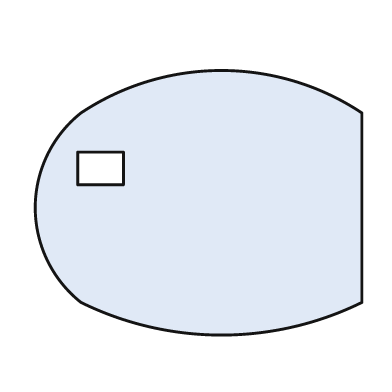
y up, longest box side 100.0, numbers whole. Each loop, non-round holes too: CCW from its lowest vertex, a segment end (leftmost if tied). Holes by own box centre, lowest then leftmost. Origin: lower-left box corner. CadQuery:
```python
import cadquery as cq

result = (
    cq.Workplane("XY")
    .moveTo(14.0, 10.0)
    .threePointArc((57.0, 0.0), (100.0, 10.0))
    .lineTo(100.0, 68.0)
    .threePointArc((57.0, 81.0), (14.0, 68.0))
    .threePointArc((0.0, 39.0), (14.0, 10.0))
    .close()
    .moveTo(13.0, 46.0)
    .lineTo(27.0, 46.0)
    .lineTo(27.0, 56.0)
    .lineTo(13.0, 56.0)
    .close()
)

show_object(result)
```